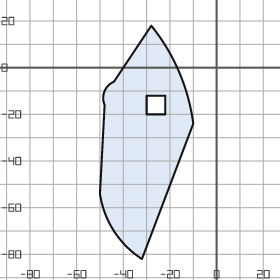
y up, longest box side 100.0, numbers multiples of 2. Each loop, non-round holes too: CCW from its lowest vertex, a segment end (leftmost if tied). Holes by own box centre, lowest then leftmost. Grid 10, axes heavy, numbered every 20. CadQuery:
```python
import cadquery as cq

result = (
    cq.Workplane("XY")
    .moveTo(-32.0, -82.0)
    .lineTo(-10.0, -24.0)
    .threePointArc((-16.0, -2.0), (-28.0, 18.0))
    .lineTo(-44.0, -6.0)
    .threePointArc((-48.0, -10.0), (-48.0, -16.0))
    .lineTo(-50.0, -54.0)
    .threePointArc((-44.0, -70.0), (-32.0, -82.0))
    .close()
    .moveTo(-30.0, -20.0)
    .lineTo(-22.0, -20.0)
    .lineTo(-22.0, -12.0)
    .lineTo(-30.0, -12.0)
    .close()
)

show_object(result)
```